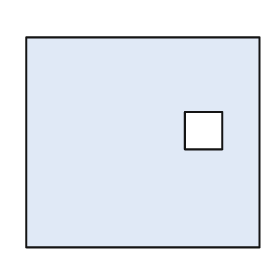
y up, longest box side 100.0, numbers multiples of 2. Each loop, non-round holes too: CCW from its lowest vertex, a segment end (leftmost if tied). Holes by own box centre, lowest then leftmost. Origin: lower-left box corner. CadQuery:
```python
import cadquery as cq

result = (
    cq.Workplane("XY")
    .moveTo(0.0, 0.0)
    .lineTo(100.0, 0.0)
    .lineTo(100.0, 90.0)
    .lineTo(0.0, 90.0)
    .close()
    .moveTo(68.0, 42.0)
    .lineTo(84.0, 42.0)
    .lineTo(84.0, 58.0)
    .lineTo(68.0, 58.0)
    .close()
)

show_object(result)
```